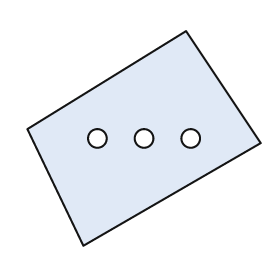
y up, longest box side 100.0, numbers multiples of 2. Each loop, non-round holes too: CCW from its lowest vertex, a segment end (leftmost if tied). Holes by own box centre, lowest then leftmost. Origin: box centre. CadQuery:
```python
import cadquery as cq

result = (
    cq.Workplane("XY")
    .moveTo(-26.0, -46.0)
    .lineTo(50.0, -2.0)
    .lineTo(18.0, 46.0)
    .lineTo(-50.0, 4.0)
    .close()
    .moveTo(-20.0, 0.0)
    .circle(4.0)
    .moveTo(0.0, 0.0)
    .circle(4.0)
    .moveTo(20.0, 0.0)
    .circle(4.0)
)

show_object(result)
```